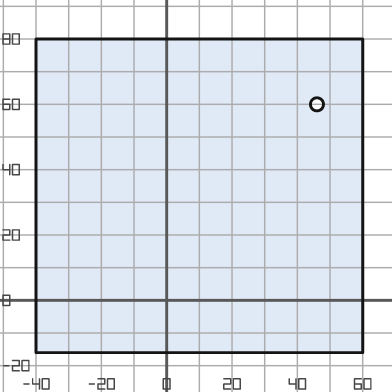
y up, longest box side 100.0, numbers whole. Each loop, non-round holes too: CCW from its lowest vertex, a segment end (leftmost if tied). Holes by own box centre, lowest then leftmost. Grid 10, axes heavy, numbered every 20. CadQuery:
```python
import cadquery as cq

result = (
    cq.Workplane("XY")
    .moveTo(-40.0, -16.0)
    .lineTo(60.0, -16.0)
    .lineTo(60.0, 80.0)
    .lineTo(-40.0, 80.0)
    .close()
    .moveTo(46.0, 60.0)
    .circle(2.0)
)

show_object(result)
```